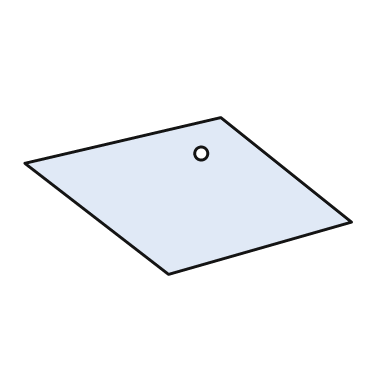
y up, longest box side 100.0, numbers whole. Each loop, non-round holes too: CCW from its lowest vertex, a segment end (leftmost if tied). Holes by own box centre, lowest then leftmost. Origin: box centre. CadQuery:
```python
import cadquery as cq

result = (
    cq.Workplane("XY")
    .moveTo(-6.0, -24.0)
    .lineTo(50.0, -8.0)
    .lineTo(10.0, 24.0)
    .lineTo(-50.0, 10.0)
    .close()
    .moveTo(4.0, 13.0)
    .circle(2.0)
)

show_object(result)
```